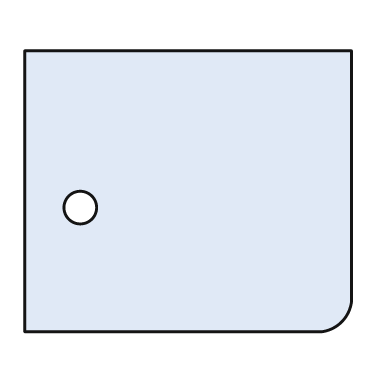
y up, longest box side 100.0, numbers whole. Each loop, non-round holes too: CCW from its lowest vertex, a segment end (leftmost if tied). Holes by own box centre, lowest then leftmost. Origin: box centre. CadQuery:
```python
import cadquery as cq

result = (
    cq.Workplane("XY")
    .moveTo(-50.0, -43.0)
    .lineTo(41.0, -43.0)
    .threePointArc((47.0, -40.0), (50.0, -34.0))
    .lineTo(50.0, 43.0)
    .lineTo(-50.0, 43.0)
    .close()
    .moveTo(-33.0, -5.0)
    .circle(5.0)
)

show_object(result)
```